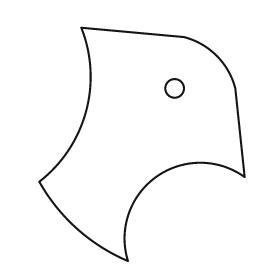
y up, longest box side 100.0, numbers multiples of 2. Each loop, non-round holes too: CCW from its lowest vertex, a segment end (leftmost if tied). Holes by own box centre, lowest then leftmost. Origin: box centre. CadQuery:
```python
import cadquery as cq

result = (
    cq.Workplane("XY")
    .moveTo(-6.0, -50.0)
    .threePointArc((6.0, -14.0), (44.0, -14.0))
    .lineTo(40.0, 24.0)
    .threePointArc((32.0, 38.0), (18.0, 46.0))
    .lineTo(-26.0, 50.0)
    .threePointArc((-24.0, 14.0), (-44.0, -16.0))
    .threePointArc((-28.0, -36.0), (-6.0, -50.0))
    .close()
    .moveTo(14.0, 24.0)
    .circle(4.0)
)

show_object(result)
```